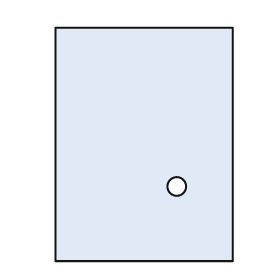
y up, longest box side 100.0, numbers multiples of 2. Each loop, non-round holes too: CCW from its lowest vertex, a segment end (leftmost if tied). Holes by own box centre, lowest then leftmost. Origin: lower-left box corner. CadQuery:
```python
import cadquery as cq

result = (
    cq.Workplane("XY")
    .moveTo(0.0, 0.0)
    .lineTo(76.0, 0.0)
    .lineTo(76.0, 100.0)
    .lineTo(0.0, 100.0)
    .close()
    .moveTo(52.0, 32.0)
    .circle(4.0)
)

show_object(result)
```